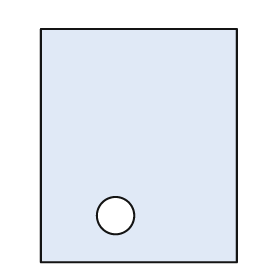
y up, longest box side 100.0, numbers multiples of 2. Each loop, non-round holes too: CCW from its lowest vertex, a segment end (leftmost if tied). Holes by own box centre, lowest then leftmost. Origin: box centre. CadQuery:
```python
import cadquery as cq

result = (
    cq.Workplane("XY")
    .moveTo(-42.0, -50.0)
    .lineTo(42.0, -50.0)
    .lineTo(42.0, 50.0)
    .lineTo(-42.0, 50.0)
    .close()
    .moveTo(-10.0, -30.0)
    .circle(8.0)
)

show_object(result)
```